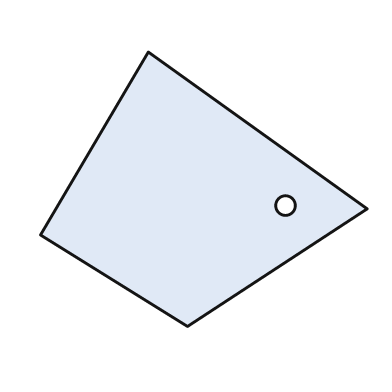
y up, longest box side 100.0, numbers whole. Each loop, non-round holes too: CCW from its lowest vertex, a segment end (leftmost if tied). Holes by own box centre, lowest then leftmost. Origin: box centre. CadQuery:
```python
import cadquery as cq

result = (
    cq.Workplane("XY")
    .moveTo(-5.0, -42.0)
    .lineTo(50.0, -6.0)
    .lineTo(-17.0, 42.0)
    .lineTo(-50.0, -14.0)
    .close()
    .moveTo(25.0, -5.0)
    .circle(3.0)
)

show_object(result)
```